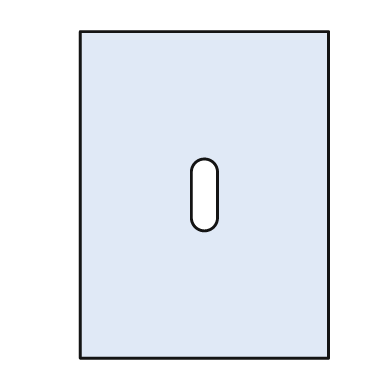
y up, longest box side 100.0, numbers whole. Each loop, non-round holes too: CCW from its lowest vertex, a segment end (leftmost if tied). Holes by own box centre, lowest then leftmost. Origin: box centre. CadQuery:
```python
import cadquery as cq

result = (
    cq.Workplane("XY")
    .moveTo(-38.0, -50.0)
    .lineTo(38.0, -50.0)
    .lineTo(38.0, 50.0)
    .lineTo(-38.0, 50.0)
    .close()
    .moveTo(-4.0, -7.0)
    .threePointArc((0.0, -11.0), (4.0, -7.0))
    .lineTo(4.0, 7.0)
    .threePointArc((0.0, 11.0), (-4.0, 7.0))
    .close()
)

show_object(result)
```